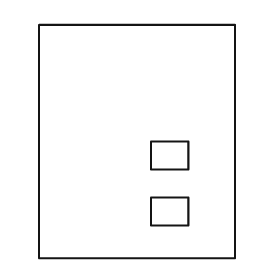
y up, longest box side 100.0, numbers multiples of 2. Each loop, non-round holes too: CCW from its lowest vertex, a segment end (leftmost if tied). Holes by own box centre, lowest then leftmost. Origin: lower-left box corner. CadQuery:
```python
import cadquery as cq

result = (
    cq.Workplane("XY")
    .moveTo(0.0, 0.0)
    .lineTo(84.0, 0.0)
    .lineTo(84.0, 100.0)
    .lineTo(0.0, 100.0)
    .close()
    .moveTo(48.0, 14.0)
    .lineTo(64.0, 14.0)
    .lineTo(64.0, 26.0)
    .lineTo(48.0, 26.0)
    .close()
    .moveTo(48.0, 38.0)
    .lineTo(64.0, 38.0)
    .lineTo(64.0, 50.0)
    .lineTo(48.0, 50.0)
    .close()
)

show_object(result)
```